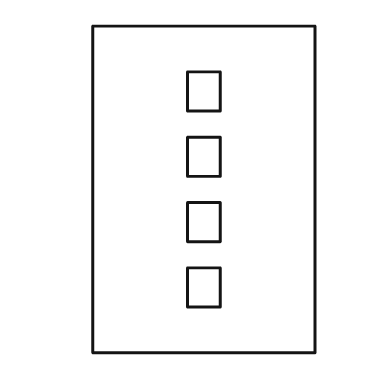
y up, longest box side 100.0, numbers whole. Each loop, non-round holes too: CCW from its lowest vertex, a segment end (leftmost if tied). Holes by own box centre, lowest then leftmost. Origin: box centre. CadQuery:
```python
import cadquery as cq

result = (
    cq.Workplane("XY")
    .moveTo(-34.0, -50.0)
    .lineTo(34.0, -50.0)
    .lineTo(34.0, 50.0)
    .lineTo(-34.0, 50.0)
    .close()
    .moveTo(-5.0, -36.0)
    .lineTo(5.0, -36.0)
    .lineTo(5.0, -24.0)
    .lineTo(-5.0, -24.0)
    .close()
    .moveTo(-5.0, -16.0)
    .lineTo(5.0, -16.0)
    .lineTo(5.0, -4.0)
    .lineTo(-5.0, -4.0)
    .close()
    .moveTo(-5.0, 4.0)
    .lineTo(5.0, 4.0)
    .lineTo(5.0, 16.0)
    .lineTo(-5.0, 16.0)
    .close()
    .moveTo(-5.0, 24.0)
    .lineTo(5.0, 24.0)
    .lineTo(5.0, 36.0)
    .lineTo(-5.0, 36.0)
    .close()
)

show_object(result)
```